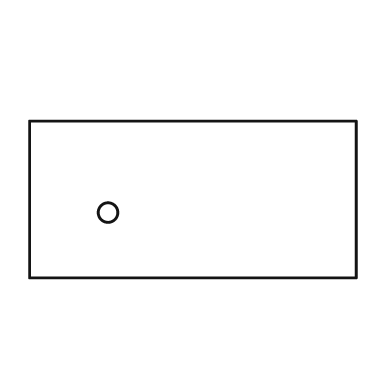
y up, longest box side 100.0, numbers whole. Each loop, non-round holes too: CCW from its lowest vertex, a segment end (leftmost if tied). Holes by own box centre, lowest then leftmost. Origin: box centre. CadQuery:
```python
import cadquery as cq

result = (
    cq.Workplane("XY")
    .moveTo(-50.0, -24.0)
    .lineTo(50.0, -24.0)
    .lineTo(50.0, 24.0)
    .lineTo(-50.0, 24.0)
    .close()
    .moveTo(-26.0, -4.0)
    .circle(3.0)
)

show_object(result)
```